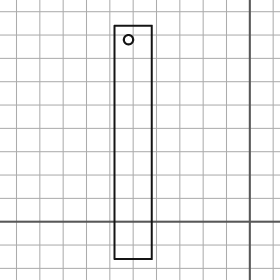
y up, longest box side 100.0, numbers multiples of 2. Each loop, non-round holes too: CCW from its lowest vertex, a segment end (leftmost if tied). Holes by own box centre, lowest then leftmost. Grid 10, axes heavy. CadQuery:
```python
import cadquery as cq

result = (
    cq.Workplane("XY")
    .moveTo(-58.0, -16.0)
    .lineTo(-42.0, -16.0)
    .lineTo(-42.0, 84.0)
    .lineTo(-58.0, 84.0)
    .close()
    .moveTo(-52.0, 78.0)
    .circle(2.0)
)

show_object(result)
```